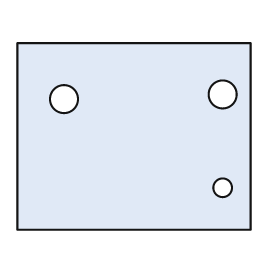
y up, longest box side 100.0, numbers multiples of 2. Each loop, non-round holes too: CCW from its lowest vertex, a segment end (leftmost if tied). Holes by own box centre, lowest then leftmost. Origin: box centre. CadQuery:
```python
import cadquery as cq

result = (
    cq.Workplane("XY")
    .moveTo(-50.0, -40.0)
    .lineTo(50.0, -40.0)
    .lineTo(50.0, 40.0)
    .lineTo(-50.0, 40.0)
    .close()
    .moveTo(38.0, -22.0)
    .circle(4.0)
    .moveTo(-30.0, 16.0)
    .circle(6.0)
    .moveTo(38.0, 18.0)
    .circle(6.0)
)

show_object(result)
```